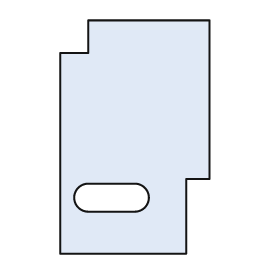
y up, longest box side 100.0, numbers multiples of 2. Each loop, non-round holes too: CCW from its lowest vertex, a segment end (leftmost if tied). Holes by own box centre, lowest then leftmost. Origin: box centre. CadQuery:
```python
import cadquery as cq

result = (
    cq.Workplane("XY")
    .moveTo(-32.0, -50.0)
    .lineTo(22.0, -50.0)
    .lineTo(22.0, -18.0)
    .lineTo(32.0, -18.0)
    .lineTo(32.0, 50.0)
    .lineTo(-20.0, 50.0)
    .lineTo(-20.0, 36.0)
    .lineTo(-32.0, 36.0)
    .close()
    .moveTo(-20.0, -32.0)
    .lineTo(0.0, -32.0)
    .threePointArc((6.0, -26.0), (0.0, -20.0))
    .lineTo(-20.0, -20.0)
    .threePointArc((-26.0, -26.0), (-20.0, -32.0))
    .close()
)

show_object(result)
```